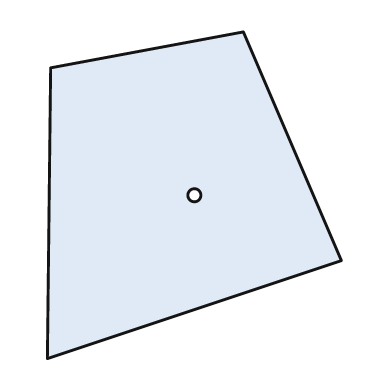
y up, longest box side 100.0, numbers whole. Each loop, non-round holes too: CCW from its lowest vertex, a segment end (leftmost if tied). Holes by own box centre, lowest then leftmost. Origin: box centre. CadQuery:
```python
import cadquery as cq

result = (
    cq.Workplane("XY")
    .moveTo(-45.0, -50.0)
    .lineTo(45.0, -20.0)
    .lineTo(15.0, 50.0)
    .lineTo(-44.0, 39.0)
    .close()
    .moveTo(0.0, 0.0)
    .circle(2.0)
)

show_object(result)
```